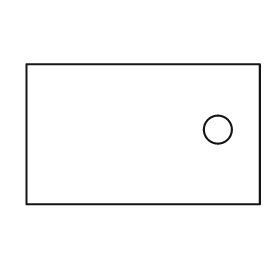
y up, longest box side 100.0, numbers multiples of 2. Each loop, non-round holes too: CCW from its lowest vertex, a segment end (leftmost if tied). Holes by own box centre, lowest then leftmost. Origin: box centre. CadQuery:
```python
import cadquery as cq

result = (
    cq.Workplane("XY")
    .moveTo(-50.0, -30.0)
    .lineTo(50.0, -30.0)
    .lineTo(50.0, 30.0)
    .lineTo(-50.0, 30.0)
    .close()
    .moveTo(32.0, 2.0)
    .circle(6.0)
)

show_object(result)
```